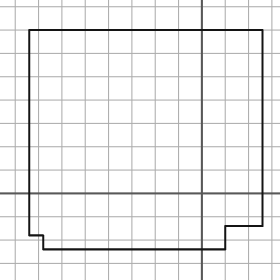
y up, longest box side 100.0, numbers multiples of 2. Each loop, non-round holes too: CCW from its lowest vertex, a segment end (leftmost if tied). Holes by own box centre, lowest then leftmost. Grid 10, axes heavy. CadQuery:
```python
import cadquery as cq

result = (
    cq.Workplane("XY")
    .moveTo(-68.0, -24.0)
    .lineTo(10.0, -24.0)
    .lineTo(10.0, -14.0)
    .lineTo(26.0, -14.0)
    .lineTo(26.0, 70.0)
    .lineTo(-74.0, 70.0)
    .lineTo(-74.0, -18.0)
    .lineTo(-68.0, -18.0)
    .close()
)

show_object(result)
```